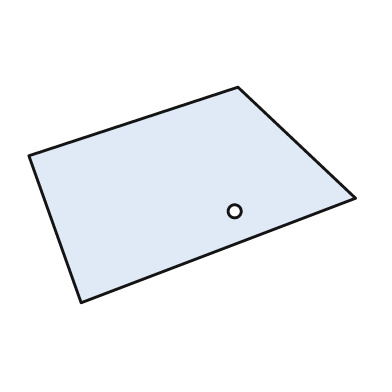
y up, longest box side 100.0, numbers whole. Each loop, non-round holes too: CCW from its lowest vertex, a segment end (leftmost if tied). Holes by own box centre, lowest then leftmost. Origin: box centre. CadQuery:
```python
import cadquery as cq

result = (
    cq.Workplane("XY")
    .moveTo(-34.0, -33.0)
    .lineTo(50.0, -1.0)
    .lineTo(14.0, 33.0)
    .lineTo(-50.0, 12.0)
    .close()
    .moveTo(13.0, -5.0)
    .circle(2.0)
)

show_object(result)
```